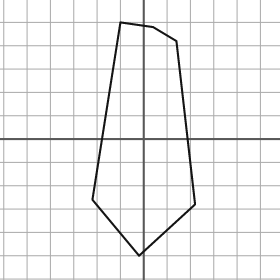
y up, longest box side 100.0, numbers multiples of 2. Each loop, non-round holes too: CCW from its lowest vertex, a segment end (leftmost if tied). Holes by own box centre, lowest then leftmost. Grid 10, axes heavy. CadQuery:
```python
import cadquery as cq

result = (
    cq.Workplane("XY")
    .moveTo(-2.0, -50.0)
    .lineTo(22.0, -28.0)
    .lineTo(14.0, 42.0)
    .lineTo(4.0, 48.0)
    .lineTo(-10.0, 50.0)
    .lineTo(-22.0, -26.0)
    .close()
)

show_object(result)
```